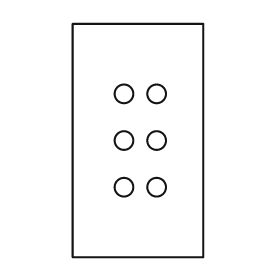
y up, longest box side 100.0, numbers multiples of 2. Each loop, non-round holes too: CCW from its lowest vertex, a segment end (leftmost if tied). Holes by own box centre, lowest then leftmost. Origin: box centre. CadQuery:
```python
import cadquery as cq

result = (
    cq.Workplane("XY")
    .moveTo(-28.0, -50.0)
    .lineTo(28.0, -50.0)
    .lineTo(28.0, 50.0)
    .lineTo(-28.0, 50.0)
    .close()
    .moveTo(-6.0, -20.0)
    .circle(4.0)
    .moveTo(8.0, -20.0)
    .circle(4.0)
    .moveTo(-6.0, 0.0)
    .circle(4.0)
    .moveTo(8.0, 0.0)
    .circle(4.0)
    .moveTo(-6.0, 20.0)
    .circle(4.0)
    .moveTo(8.0, 20.0)
    .circle(4.0)
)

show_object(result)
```